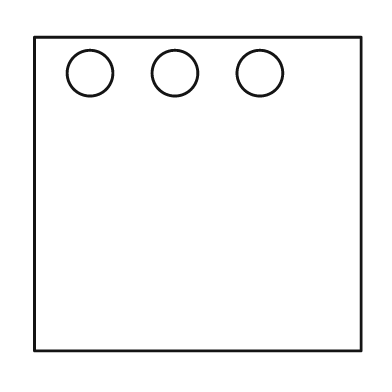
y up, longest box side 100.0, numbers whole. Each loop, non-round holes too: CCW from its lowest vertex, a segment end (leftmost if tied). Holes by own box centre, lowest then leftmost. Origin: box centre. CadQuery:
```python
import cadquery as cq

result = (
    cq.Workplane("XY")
    .moveTo(-50.0, -48.0)
    .lineTo(50.0, -48.0)
    .lineTo(50.0, 48.0)
    .lineTo(-50.0, 48.0)
    .close()
    .moveTo(-33.0, 37.0)
    .circle(7.0)
    .moveTo(-7.0, 37.0)
    .circle(7.0)
    .moveTo(19.0, 37.0)
    .circle(7.0)
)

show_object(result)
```